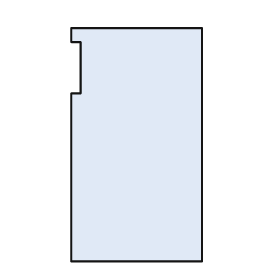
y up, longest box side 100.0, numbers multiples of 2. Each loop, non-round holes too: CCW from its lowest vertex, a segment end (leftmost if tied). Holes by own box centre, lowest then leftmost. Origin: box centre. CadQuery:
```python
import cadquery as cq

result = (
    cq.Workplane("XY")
    .moveTo(-28.0, -50.0)
    .lineTo(28.0, -50.0)
    .lineTo(28.0, 50.0)
    .lineTo(-28.0, 50.0)
    .lineTo(-28.0, 44.0)
    .lineTo(-24.0, 44.0)
    .lineTo(-24.0, 22.0)
    .lineTo(-28.0, 22.0)
    .close()
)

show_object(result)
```